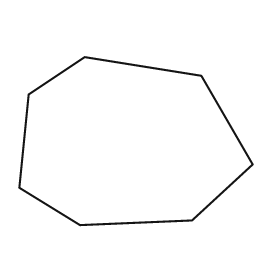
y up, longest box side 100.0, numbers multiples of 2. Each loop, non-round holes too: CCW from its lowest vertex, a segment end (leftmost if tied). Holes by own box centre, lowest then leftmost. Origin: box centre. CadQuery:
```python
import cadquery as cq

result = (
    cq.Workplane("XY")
    .moveTo(-24.0, -36.0)
    .lineTo(24.0, -34.0)
    .lineTo(50.0, -10.0)
    .lineTo(28.0, 28.0)
    .lineTo(-22.0, 36.0)
    .lineTo(-46.0, 20.0)
    .lineTo(-50.0, -20.0)
    .close()
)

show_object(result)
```